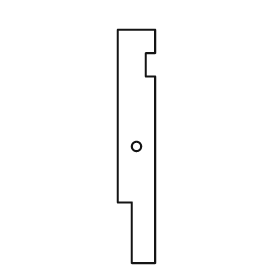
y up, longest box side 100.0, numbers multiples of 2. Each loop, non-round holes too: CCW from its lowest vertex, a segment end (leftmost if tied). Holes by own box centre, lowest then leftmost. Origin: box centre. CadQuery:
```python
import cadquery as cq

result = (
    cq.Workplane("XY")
    .moveTo(-2.0, -50.0)
    .lineTo(8.0, -50.0)
    .lineTo(8.0, 30.0)
    .lineTo(4.0, 30.0)
    .lineTo(4.0, 40.0)
    .lineTo(8.0, 40.0)
    .lineTo(8.0, 50.0)
    .lineTo(-8.0, 50.0)
    .lineTo(-8.0, -24.0)
    .lineTo(-2.0, -24.0)
    .close()
    .moveTo(0.0, 0.0)
    .circle(2.0)
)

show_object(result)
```